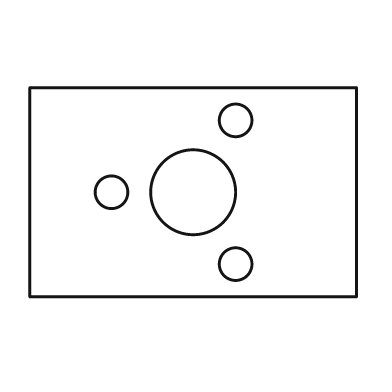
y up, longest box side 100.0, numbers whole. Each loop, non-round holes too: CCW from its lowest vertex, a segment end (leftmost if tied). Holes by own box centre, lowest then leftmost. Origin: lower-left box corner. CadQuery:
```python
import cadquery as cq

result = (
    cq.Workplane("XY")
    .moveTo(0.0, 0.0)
    .lineTo(100.0, 0.0)
    .lineTo(100.0, 64.0)
    .lineTo(0.0, 64.0)
    .close()
    .moveTo(63.0, 10.0)
    .circle(5.0)
    .moveTo(25.0, 32.0)
    .circle(5.0)
    .moveTo(50.0, 32.0)
    .circle(13.0)
    .moveTo(63.0, 54.0)
    .circle(5.0)
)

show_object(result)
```